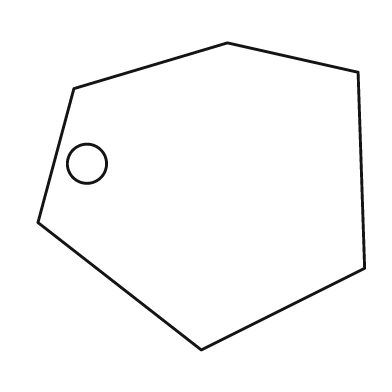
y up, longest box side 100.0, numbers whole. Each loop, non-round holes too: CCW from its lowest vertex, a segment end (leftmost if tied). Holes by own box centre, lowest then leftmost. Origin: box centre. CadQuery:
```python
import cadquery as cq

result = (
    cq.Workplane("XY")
    .moveTo(0.0, -47.0)
    .lineTo(50.0, -22.0)
    .lineTo(48.0, 38.0)
    .lineTo(8.0, 47.0)
    .lineTo(-39.0, 33.0)
    .lineTo(-50.0, -8.0)
    .close()
    .moveTo(-35.0, 10.0)
    .circle(6.0)
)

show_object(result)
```